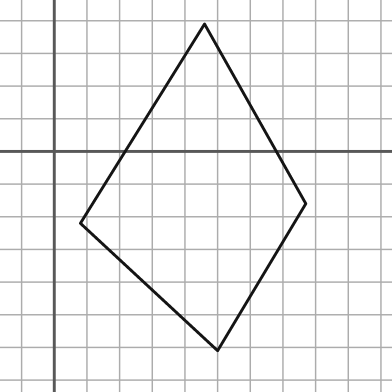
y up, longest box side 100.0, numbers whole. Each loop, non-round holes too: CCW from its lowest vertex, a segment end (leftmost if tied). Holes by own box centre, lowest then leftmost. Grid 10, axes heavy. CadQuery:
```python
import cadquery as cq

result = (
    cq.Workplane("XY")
    .moveTo(50.0, -61.0)
    .lineTo(77.0, -16.0)
    .lineTo(46.0, 39.0)
    .lineTo(8.0, -22.0)
    .close()
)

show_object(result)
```